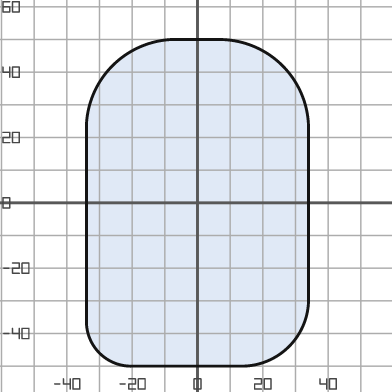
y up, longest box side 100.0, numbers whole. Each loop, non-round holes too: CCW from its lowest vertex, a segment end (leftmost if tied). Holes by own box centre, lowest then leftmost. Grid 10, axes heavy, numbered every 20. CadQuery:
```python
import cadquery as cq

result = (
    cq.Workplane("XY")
    .moveTo(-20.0, -50.0)
    .lineTo(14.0, -50.0)
    .threePointArc((28.0, -44.0), (34.0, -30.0))
    .lineTo(34.0, 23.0)
    .threePointArc((26.0, 42.0), (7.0, 50.0))
    .lineTo(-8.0, 50.0)
    .threePointArc((-26.0, 42.0), (-34.0, 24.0))
    .lineTo(-34.0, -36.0)
    .threePointArc((-30.0, -46.0), (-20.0, -50.0))
    .close()
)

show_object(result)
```